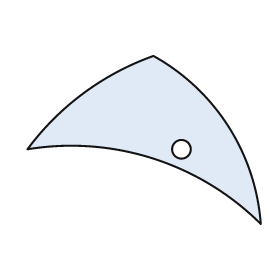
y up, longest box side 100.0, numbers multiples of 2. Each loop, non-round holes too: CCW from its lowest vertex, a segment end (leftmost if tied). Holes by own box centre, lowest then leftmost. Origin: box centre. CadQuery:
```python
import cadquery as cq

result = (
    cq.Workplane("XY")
    .moveTo(50.0, -36.0)
    .threePointArc((36.0, 6.0), (4.0, 36.0))
    .threePointArc((-26.0, 20.0), (-50.0, -4.0))
    .threePointArc((4.0, -8.0), (50.0, -36.0))
    .close()
    .moveTo(16.0, -4.0)
    .circle(4.0)
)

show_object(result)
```